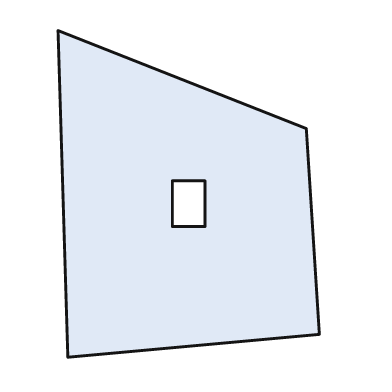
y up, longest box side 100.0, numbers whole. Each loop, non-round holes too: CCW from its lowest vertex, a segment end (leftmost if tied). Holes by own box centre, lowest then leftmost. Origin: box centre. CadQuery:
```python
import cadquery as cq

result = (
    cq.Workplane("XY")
    .moveTo(-37.0, -50.0)
    .lineTo(40.0, -43.0)
    .lineTo(36.0, 20.0)
    .lineTo(-40.0, 50.0)
    .close()
    .moveTo(-5.0, -10.0)
    .lineTo(5.0, -10.0)
    .lineTo(5.0, 4.0)
    .lineTo(-5.0, 4.0)
    .close()
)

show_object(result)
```